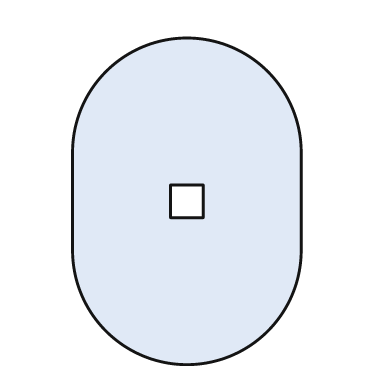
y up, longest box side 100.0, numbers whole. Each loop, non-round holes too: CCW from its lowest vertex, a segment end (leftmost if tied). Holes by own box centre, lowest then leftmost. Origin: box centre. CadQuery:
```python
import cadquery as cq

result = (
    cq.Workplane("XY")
    .moveTo(-35.0, -15.0)
    .threePointArc((0.0, -50.0), (35.0, -15.0))
    .lineTo(35.0, 15.0)
    .threePointArc((0.0, 50.0), (-35.0, 15.0))
    .close()
    .moveTo(-5.0, -5.0)
    .lineTo(5.0, -5.0)
    .lineTo(5.0, 5.0)
    .lineTo(-5.0, 5.0)
    .close()
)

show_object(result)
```